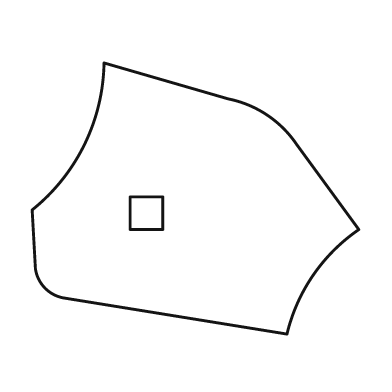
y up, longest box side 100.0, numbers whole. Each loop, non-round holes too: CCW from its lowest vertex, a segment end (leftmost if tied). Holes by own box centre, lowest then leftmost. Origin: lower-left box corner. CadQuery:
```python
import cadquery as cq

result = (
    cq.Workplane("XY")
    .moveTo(78.0, 0.0)
    .threePointArc((86.0, 18.0), (100.0, 32.0))
    .lineTo(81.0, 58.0)
    .threePointArc((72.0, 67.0), (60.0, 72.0))
    .lineTo(22.0, 83.0)
    .threePointArc((16.0, 58.0), (0.0, 38.0))
    .lineTo(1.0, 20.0)
    .threePointArc((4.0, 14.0), (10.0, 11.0))
    .close()
    .moveTo(30.0, 32.0)
    .lineTo(40.0, 32.0)
    .lineTo(40.0, 42.0)
    .lineTo(30.0, 42.0)
    .close()
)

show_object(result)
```